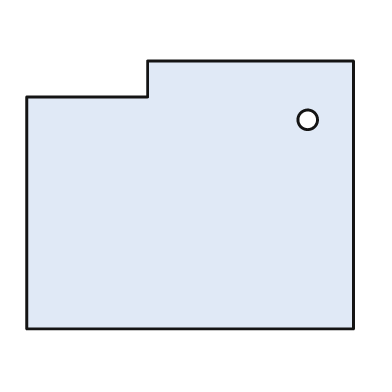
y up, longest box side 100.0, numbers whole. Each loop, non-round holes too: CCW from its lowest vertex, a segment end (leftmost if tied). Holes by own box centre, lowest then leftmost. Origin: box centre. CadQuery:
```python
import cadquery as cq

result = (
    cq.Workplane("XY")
    .moveTo(-50.0, -41.0)
    .lineTo(50.0, -41.0)
    .lineTo(50.0, 41.0)
    .lineTo(-13.0, 41.0)
    .lineTo(-13.0, 30.0)
    .lineTo(-50.0, 30.0)
    .close()
    .moveTo(36.0, 23.0)
    .circle(3.0)
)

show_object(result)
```